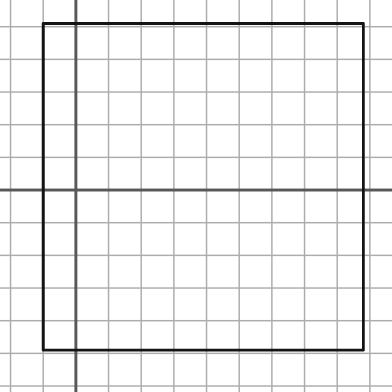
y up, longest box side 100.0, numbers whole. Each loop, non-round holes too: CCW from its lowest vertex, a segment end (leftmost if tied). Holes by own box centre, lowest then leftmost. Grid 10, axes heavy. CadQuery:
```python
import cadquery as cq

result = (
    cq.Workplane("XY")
    .moveTo(-10.0, -49.0)
    .lineTo(88.0, -49.0)
    .lineTo(88.0, 51.0)
    .lineTo(-10.0, 51.0)
    .close()
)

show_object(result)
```